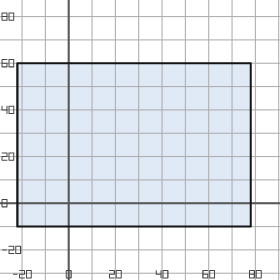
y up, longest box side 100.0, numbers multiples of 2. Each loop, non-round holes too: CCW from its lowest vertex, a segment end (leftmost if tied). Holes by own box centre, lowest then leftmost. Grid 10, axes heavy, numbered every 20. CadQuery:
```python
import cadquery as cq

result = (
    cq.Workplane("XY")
    .moveTo(-22.0, -10.0)
    .lineTo(78.0, -10.0)
    .lineTo(78.0, 60.0)
    .lineTo(-22.0, 60.0)
    .close()
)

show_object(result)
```